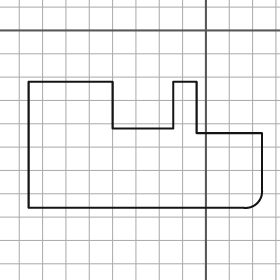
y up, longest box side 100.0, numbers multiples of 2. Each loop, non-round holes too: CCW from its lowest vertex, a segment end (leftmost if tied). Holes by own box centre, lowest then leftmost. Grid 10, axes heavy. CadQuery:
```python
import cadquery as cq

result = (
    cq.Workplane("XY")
    .moveTo(-76.0, -76.0)
    .lineTo(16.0, -76.0)
    .threePointArc((22.0, -74.0), (24.0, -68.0))
    .lineTo(24.0, -44.0)
    .lineTo(-4.0, -44.0)
    .lineTo(-4.0, -22.0)
    .lineTo(-14.0, -22.0)
    .lineTo(-14.0, -42.0)
    .lineTo(-40.0, -42.0)
    .lineTo(-40.0, -22.0)
    .lineTo(-76.0, -22.0)
    .close()
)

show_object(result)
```